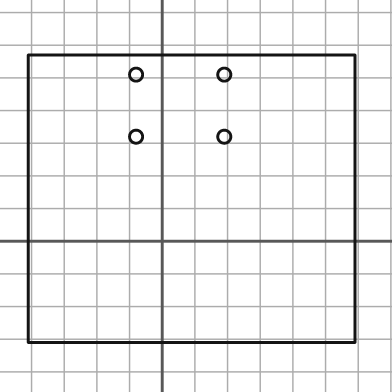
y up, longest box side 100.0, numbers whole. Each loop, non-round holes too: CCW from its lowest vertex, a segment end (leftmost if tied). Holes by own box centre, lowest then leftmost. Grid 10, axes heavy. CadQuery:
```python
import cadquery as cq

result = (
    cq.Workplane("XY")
    .moveTo(-41.0, -31.0)
    .lineTo(59.0, -31.0)
    .lineTo(59.0, 57.0)
    .lineTo(-41.0, 57.0)
    .close()
    .moveTo(-8.0, 32.0)
    .circle(2.0)
    .moveTo(19.0, 32.0)
    .circle(2.0)
    .moveTo(-8.0, 51.0)
    .circle(2.0)
    .moveTo(19.0, 51.0)
    .circle(2.0)
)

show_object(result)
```